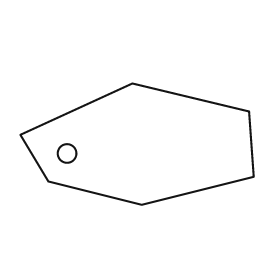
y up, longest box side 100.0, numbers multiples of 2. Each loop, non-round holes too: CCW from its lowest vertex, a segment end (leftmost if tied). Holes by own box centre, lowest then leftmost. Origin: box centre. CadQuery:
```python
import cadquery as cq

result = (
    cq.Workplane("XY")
    .moveTo(2.0, -26.0)
    .lineTo(50.0, -14.0)
    .lineTo(48.0, 14.0)
    .lineTo(-2.0, 26.0)
    .lineTo(-50.0, 4.0)
    .lineTo(-38.0, -16.0)
    .close()
    .moveTo(-30.0, -4.0)
    .circle(4.0)
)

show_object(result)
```